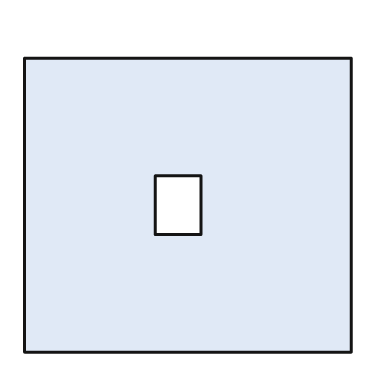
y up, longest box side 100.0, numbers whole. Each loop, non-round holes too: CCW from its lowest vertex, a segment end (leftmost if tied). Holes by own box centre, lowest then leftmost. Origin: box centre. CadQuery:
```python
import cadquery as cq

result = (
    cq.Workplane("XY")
    .moveTo(-50.0, -45.0)
    .lineTo(50.0, -45.0)
    .lineTo(50.0, 45.0)
    .lineTo(-50.0, 45.0)
    .close()
    .moveTo(-10.0, -9.0)
    .lineTo(4.0, -9.0)
    .lineTo(4.0, 9.0)
    .lineTo(-10.0, 9.0)
    .close()
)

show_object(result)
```